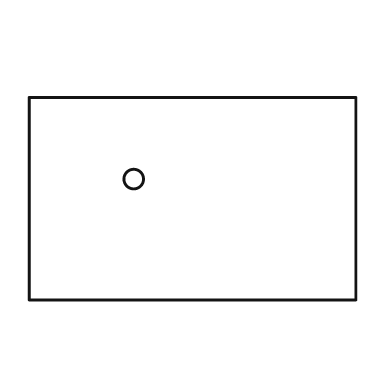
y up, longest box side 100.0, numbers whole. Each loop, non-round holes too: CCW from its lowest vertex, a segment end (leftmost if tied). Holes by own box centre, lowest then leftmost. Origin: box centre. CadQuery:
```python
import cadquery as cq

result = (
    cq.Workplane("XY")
    .moveTo(-50.0, -31.0)
    .lineTo(50.0, -31.0)
    .lineTo(50.0, 31.0)
    .lineTo(-50.0, 31.0)
    .close()
    .moveTo(-18.0, 6.0)
    .circle(3.0)
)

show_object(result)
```